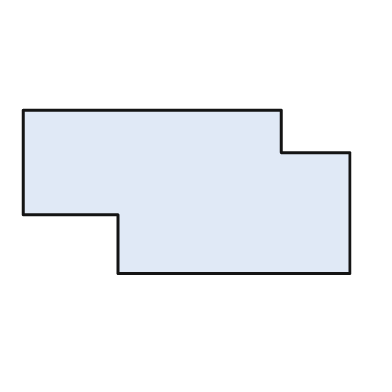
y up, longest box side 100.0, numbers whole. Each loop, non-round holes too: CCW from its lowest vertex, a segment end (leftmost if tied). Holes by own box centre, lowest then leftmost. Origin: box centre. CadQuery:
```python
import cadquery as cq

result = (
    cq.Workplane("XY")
    .moveTo(-21.0, -25.0)
    .lineTo(50.0, -25.0)
    .lineTo(50.0, 12.0)
    .lineTo(29.0, 12.0)
    .lineTo(29.0, 25.0)
    .lineTo(-50.0, 25.0)
    .lineTo(-50.0, -7.0)
    .lineTo(-21.0, -7.0)
    .close()
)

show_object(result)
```